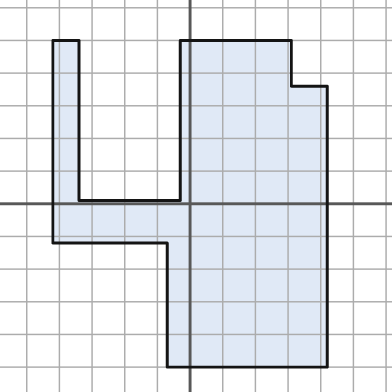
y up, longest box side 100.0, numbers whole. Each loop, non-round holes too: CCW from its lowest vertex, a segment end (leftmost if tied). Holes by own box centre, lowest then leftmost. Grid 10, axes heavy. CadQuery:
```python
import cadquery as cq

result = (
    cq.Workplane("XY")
    .moveTo(-7.0, -50.0)
    .lineTo(42.0, -50.0)
    .lineTo(42.0, 36.0)
    .lineTo(31.0, 36.0)
    .lineTo(31.0, 50.0)
    .lineTo(-3.0, 50.0)
    .lineTo(-3.0, 1.0)
    .lineTo(-34.0, 1.0)
    .lineTo(-34.0, 50.0)
    .lineTo(-42.0, 50.0)
    .lineTo(-42.0, -12.0)
    .lineTo(-7.0, -12.0)
    .close()
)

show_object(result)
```